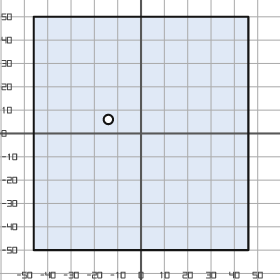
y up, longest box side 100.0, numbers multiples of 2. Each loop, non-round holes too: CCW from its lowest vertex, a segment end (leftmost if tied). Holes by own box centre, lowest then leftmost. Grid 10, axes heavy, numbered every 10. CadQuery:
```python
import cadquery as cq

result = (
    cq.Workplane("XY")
    .moveTo(-46.0, -50.0)
    .lineTo(46.0, -50.0)
    .lineTo(46.0, 50.0)
    .lineTo(-46.0, 50.0)
    .close()
    .moveTo(-14.0, 6.0)
    .circle(2.0)
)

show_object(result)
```